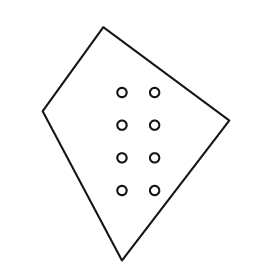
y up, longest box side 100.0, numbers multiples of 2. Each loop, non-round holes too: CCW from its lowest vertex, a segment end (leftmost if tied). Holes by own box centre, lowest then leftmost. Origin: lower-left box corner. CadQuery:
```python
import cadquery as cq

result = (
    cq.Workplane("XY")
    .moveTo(34.0, 0.0)
    .lineTo(80.0, 60.0)
    .lineTo(26.0, 100.0)
    .lineTo(0.0, 64.0)
    .close()
    .moveTo(34.0, 30.0)
    .circle(2.0)
    .moveTo(48.0, 30.0)
    .circle(2.0)
    .moveTo(34.0, 44.0)
    .circle(2.0)
    .moveTo(48.0, 44.0)
    .circle(2.0)
    .moveTo(34.0, 58.0)
    .circle(2.0)
    .moveTo(48.0, 58.0)
    .circle(2.0)
    .moveTo(34.0, 72.0)
    .circle(2.0)
    .moveTo(48.0, 72.0)
    .circle(2.0)
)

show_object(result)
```